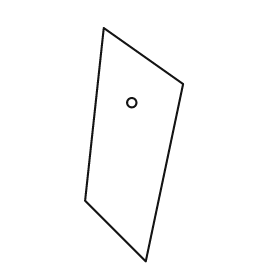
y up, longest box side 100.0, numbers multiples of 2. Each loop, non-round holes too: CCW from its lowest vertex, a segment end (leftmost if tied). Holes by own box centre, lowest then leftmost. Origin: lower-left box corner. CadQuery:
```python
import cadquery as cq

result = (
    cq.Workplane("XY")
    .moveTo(26.0, 0.0)
    .lineTo(42.0, 76.0)
    .lineTo(8.0, 100.0)
    .lineTo(0.0, 26.0)
    .close()
    .moveTo(20.0, 68.0)
    .circle(2.0)
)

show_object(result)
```